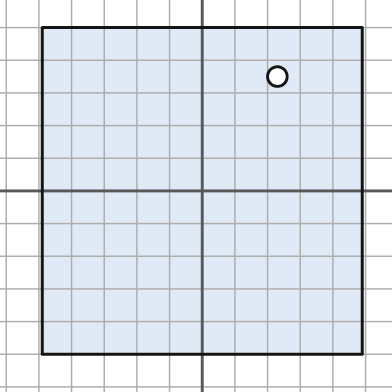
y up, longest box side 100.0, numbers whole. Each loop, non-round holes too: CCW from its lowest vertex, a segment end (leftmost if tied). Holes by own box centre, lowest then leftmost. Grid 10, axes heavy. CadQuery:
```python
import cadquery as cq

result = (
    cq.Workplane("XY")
    .moveTo(-49.0, -50.0)
    .lineTo(49.0, -50.0)
    .lineTo(49.0, 50.0)
    .lineTo(-49.0, 50.0)
    .close()
    .moveTo(23.0, 35.0)
    .circle(3.0)
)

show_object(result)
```